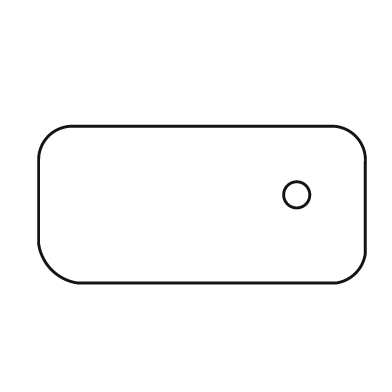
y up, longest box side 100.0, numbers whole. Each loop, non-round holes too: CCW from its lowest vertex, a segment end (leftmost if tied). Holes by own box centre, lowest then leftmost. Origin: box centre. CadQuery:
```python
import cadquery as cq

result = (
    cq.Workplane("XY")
    .moveTo(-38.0, -24.0)
    .lineTo(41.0, -24.0)
    .threePointArc((47.0, -21.0), (50.0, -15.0))
    .lineTo(50.0, 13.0)
    .threePointArc((47.0, 21.0), (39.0, 24.0))
    .lineTo(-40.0, 24.0)
    .threePointArc((-47.0, 21.0), (-50.0, 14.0))
    .lineTo(-50.0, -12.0)
    .threePointArc((-46.0, -20.0), (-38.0, -24.0))
    .close()
    .moveTo(29.0, 3.0)
    .circle(4.0)
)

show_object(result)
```